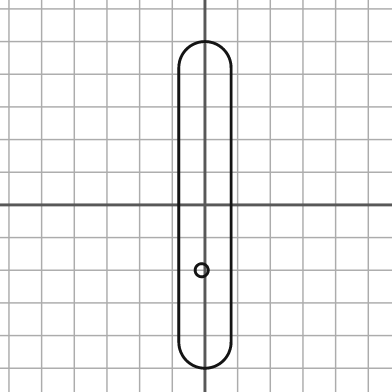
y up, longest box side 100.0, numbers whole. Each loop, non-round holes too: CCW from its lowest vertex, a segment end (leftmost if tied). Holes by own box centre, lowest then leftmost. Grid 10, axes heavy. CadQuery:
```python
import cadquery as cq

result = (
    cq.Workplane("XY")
    .moveTo(-8.0, -42.0)
    .threePointArc((0.0, -50.0), (8.0, -42.0))
    .lineTo(8.0, 42.0)
    .threePointArc((0.0, 50.0), (-8.0, 42.0))
    .close()
    .moveTo(-1.0, -20.0)
    .circle(2.0)
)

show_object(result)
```